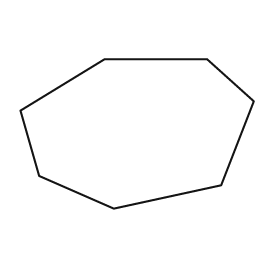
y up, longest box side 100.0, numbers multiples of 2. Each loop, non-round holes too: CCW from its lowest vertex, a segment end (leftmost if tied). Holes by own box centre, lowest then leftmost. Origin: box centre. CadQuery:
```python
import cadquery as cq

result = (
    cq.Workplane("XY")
    .moveTo(-10.0, -32.0)
    .lineTo(36.0, -22.0)
    .lineTo(50.0, 14.0)
    .lineTo(30.0, 32.0)
    .lineTo(-14.0, 32.0)
    .lineTo(-50.0, 10.0)
    .lineTo(-42.0, -18.0)
    .close()
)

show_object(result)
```